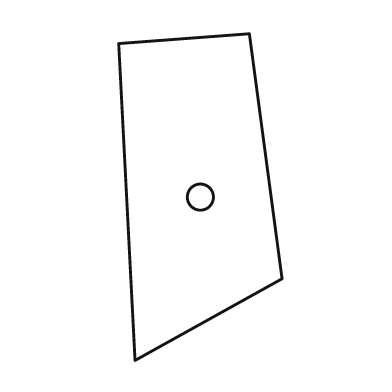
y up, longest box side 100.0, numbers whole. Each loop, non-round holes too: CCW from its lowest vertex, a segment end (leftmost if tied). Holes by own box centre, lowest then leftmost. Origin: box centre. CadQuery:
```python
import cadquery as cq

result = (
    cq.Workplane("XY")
    .moveTo(-20.0, -50.0)
    .lineTo(25.0, -25.0)
    .lineTo(15.0, 50.0)
    .lineTo(-25.0, 47.0)
    .close()
    .moveTo(0.0, 0.0)
    .circle(4.0)
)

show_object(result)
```